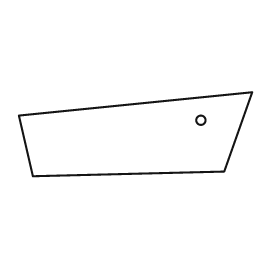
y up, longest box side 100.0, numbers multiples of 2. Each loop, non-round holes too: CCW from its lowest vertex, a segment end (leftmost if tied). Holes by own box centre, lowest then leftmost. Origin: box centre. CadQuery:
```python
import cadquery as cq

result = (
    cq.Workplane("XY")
    .moveTo(-44.0, -18.0)
    .lineTo(38.0, -16.0)
    .lineTo(50.0, 18.0)
    .lineTo(-50.0, 8.0)
    .close()
    .moveTo(28.0, 6.0)
    .circle(2.0)
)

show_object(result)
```